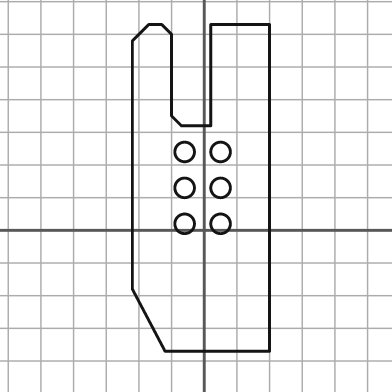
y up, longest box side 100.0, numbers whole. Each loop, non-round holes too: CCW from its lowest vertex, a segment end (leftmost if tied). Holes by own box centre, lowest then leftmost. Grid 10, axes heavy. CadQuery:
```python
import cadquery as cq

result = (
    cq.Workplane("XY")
    .moveTo(-12.0, -37.0)
    .lineTo(20.0, -37.0)
    .lineTo(20.0, 63.0)
    .lineTo(2.0, 63.0)
    .lineTo(2.0, 32.0)
    .lineTo(-7.0, 32.0)
    .lineTo(-10.0, 35.0)
    .lineTo(-10.0, 60.0)
    .lineTo(-13.0, 63.0)
    .lineTo(-17.0, 63.0)
    .lineTo(-22.0, 58.0)
    .lineTo(-22.0, -18.0)
    .close()
    .moveTo(-6.0, 2.0)
    .circle(3.0)
    .moveTo(5.0, 2.0)
    .circle(3.0)
    .moveTo(-6.0, 13.0)
    .circle(3.0)
    .moveTo(5.0, 13.0)
    .circle(3.0)
    .moveTo(-6.0, 24.0)
    .circle(3.0)
    .moveTo(5.0, 24.0)
    .circle(3.0)
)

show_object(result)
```